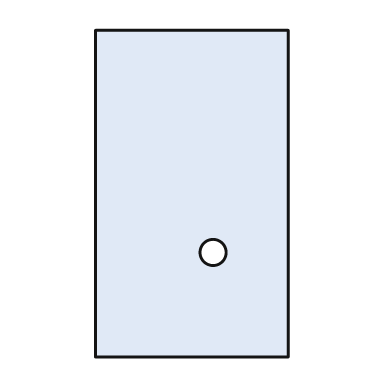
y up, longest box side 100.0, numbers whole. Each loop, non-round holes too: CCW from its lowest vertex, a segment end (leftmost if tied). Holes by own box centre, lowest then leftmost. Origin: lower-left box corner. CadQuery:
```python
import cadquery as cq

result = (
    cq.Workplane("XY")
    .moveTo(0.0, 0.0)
    .lineTo(59.0, 0.0)
    .lineTo(59.0, 100.0)
    .lineTo(0.0, 100.0)
    .close()
    .moveTo(36.0, 32.0)
    .circle(4.0)
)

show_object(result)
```